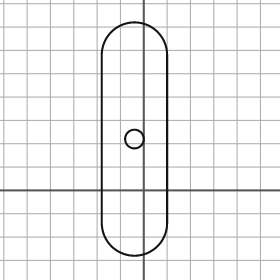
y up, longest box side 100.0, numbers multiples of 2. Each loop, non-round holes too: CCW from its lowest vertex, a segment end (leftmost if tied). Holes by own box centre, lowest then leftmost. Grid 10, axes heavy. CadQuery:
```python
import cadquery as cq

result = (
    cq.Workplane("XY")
    .moveTo(-18.0, -14.0)
    .threePointArc((-4.0, -28.0), (10.0, -14.0))
    .lineTo(10.0, 58.0)
    .threePointArc((-4.0, 72.0), (-18.0, 58.0))
    .close()
    .moveTo(-4.0, 22.0)
    .circle(4.0)
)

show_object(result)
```